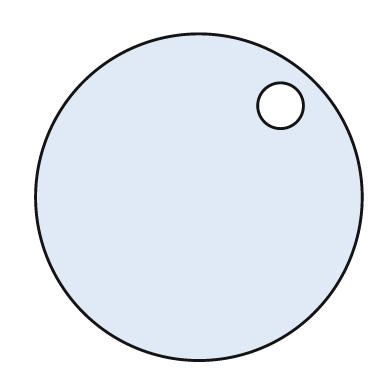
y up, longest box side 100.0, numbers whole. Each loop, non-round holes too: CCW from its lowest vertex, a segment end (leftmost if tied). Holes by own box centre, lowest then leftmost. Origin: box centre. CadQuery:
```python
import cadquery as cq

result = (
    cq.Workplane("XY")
    .moveTo(0.0, 0.0)
    .circle(50.0)
    .moveTo(25.0, 28.0)
    .circle(7.0)
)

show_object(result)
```